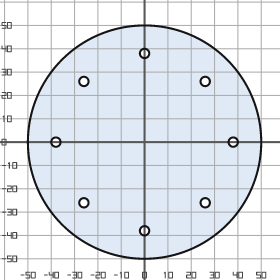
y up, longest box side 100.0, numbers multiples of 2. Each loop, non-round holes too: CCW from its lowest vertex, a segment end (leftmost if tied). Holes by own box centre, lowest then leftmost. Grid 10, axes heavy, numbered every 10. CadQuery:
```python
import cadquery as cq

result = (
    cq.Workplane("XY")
    .moveTo(0.0, 0.0)
    .circle(50.0)
    .moveTo(0.0, -38.0)
    .circle(2.0)
    .moveTo(-26.0, -26.0)
    .circle(2.0)
    .moveTo(26.0, -26.0)
    .circle(2.0)
    .moveTo(-38.0, 0.0)
    .circle(2.0)
    .moveTo(38.0, 0.0)
    .circle(2.0)
    .moveTo(-26.0, 26.0)
    .circle(2.0)
    .moveTo(26.0, 26.0)
    .circle(2.0)
    .moveTo(0.0, 38.0)
    .circle(2.0)
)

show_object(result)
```